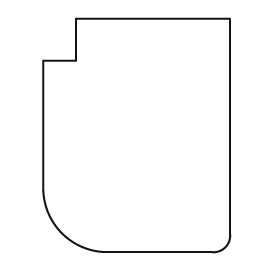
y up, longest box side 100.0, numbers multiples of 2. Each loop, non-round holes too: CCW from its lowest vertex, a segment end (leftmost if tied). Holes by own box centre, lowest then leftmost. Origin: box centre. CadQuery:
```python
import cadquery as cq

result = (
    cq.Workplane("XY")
    .moveTo(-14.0, -50.0)
    .lineTo(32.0, -50.0)
    .threePointArc((38.0, -48.0), (40.0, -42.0))
    .lineTo(40.0, 50.0)
    .lineTo(-26.0, 50.0)
    .lineTo(-26.0, 32.0)
    .lineTo(-40.0, 32.0)
    .lineTo(-40.0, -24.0)
    .threePointArc((-32.0, -42.0), (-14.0, -50.0))
    .close()
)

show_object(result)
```